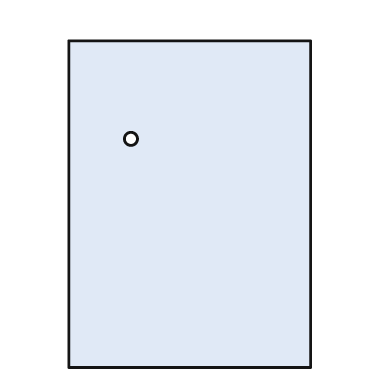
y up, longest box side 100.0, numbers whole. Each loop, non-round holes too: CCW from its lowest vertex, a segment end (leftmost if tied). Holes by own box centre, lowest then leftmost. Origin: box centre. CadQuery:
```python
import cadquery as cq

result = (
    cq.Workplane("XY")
    .moveTo(-37.0, -50.0)
    .lineTo(37.0, -50.0)
    .lineTo(37.0, 50.0)
    .lineTo(-37.0, 50.0)
    .close()
    .moveTo(-18.0, 20.0)
    .circle(2.0)
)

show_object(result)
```